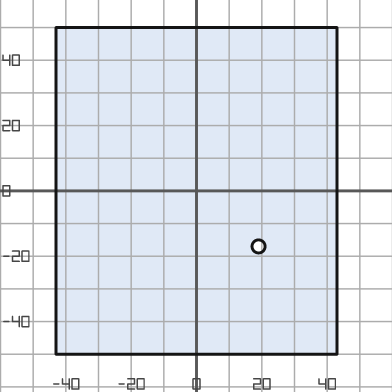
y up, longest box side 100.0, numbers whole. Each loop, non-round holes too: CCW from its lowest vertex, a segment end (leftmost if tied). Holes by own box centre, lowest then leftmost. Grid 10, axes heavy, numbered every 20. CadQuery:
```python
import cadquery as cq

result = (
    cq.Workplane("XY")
    .moveTo(-43.0, -50.0)
    .lineTo(43.0, -50.0)
    .lineTo(43.0, 50.0)
    .lineTo(-43.0, 50.0)
    .close()
    .moveTo(19.0, -17.0)
    .circle(2.0)
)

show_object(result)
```